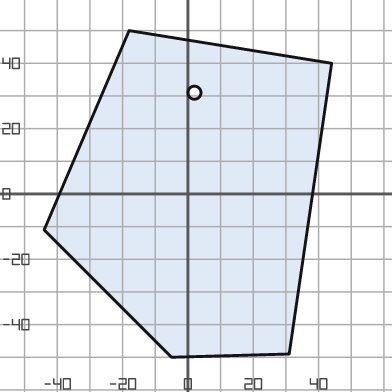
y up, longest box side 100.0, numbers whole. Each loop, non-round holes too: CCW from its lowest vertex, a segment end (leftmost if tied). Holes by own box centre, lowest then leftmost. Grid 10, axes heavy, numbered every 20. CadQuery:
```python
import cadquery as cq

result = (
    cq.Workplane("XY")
    .moveTo(-5.0, -50.0)
    .lineTo(31.0, -49.0)
    .lineTo(44.0, 40.0)
    .lineTo(-18.0, 50.0)
    .lineTo(-44.0, -11.0)
    .close()
    .moveTo(2.0, 31.0)
    .circle(2.0)
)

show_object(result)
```